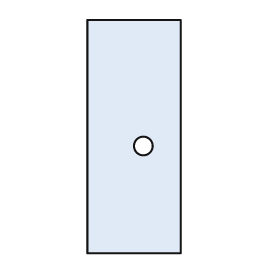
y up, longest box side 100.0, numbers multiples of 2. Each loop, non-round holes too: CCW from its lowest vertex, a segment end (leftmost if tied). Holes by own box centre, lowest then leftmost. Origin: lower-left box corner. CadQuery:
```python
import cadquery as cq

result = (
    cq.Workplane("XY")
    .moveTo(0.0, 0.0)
    .lineTo(40.0, 0.0)
    .lineTo(40.0, 100.0)
    .lineTo(0.0, 100.0)
    .close()
    .moveTo(24.0, 46.0)
    .circle(4.0)
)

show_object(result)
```